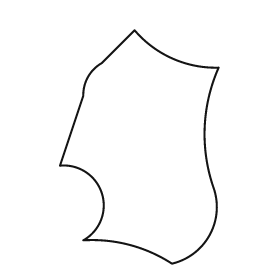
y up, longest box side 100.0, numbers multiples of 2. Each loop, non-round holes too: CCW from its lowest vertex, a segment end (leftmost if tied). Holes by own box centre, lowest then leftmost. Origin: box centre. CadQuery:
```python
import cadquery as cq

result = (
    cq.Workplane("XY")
    .moveTo(14.0, -50.0)
    .threePointArc((30.0, -38.0), (32.0, -18.0))
    .threePointArc((28.0, 8.0), (34.0, 34.0))
    .threePointArc((14.0, 38.0), (-2.0, 50.0))
    .lineTo(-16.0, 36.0)
    .threePointArc((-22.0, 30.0), (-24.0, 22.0))
    .lineTo(-34.0, -8.0)
    .threePointArc((-16.0, -20.0), (-24.0, -40.0))
    .threePointArc((-4.0, -42.0), (14.0, -50.0))
    .close()
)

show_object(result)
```